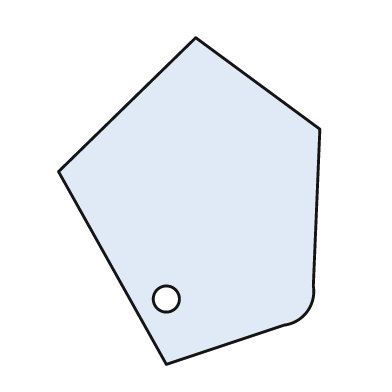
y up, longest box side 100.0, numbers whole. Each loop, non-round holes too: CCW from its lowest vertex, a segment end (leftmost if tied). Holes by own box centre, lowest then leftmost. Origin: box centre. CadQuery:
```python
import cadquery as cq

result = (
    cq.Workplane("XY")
    .moveTo(-7.0, -50.0)
    .lineTo(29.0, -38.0)
    .threePointArc((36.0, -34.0), (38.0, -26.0))
    .lineTo(40.0, 22.0)
    .lineTo(2.0, 50.0)
    .lineTo(-40.0, 9.0)
    .close()
    .moveTo(-7.0, -30.0)
    .circle(4.0)
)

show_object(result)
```